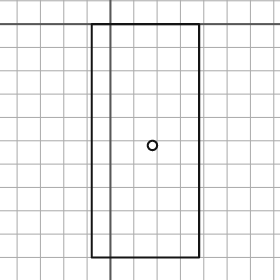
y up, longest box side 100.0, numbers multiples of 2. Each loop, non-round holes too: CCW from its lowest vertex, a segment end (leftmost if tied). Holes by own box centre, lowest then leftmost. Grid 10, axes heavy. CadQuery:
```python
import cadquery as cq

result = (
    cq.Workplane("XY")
    .moveTo(-8.0, -100.0)
    .lineTo(38.0, -100.0)
    .lineTo(38.0, 0.0)
    .lineTo(-8.0, 0.0)
    .close()
    .moveTo(18.0, -52.0)
    .circle(2.0)
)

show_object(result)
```